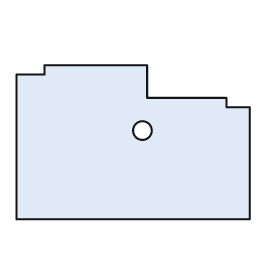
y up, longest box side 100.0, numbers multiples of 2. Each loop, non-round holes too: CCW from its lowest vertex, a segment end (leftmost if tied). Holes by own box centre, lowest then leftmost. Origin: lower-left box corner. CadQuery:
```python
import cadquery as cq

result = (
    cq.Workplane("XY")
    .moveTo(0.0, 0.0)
    .lineTo(100.0, 0.0)
    .lineTo(100.0, 48.0)
    .lineTo(90.0, 48.0)
    .lineTo(90.0, 52.0)
    .lineTo(56.0, 52.0)
    .lineTo(56.0, 66.0)
    .lineTo(12.0, 66.0)
    .lineTo(12.0, 62.0)
    .lineTo(0.0, 62.0)
    .close()
    .moveTo(54.0, 38.0)
    .circle(4.0)
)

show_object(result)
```